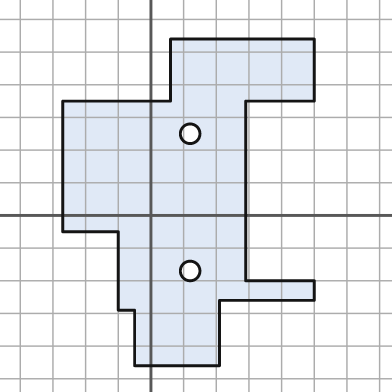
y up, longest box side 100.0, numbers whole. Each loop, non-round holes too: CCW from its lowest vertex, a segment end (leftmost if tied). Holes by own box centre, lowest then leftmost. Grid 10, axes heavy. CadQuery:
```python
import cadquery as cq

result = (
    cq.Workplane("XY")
    .moveTo(-5.0, -46.0)
    .lineTo(21.0, -46.0)
    .lineTo(21.0, -26.0)
    .lineTo(50.0, -26.0)
    .lineTo(50.0, -20.0)
    .lineTo(29.0, -20.0)
    .lineTo(29.0, 35.0)
    .lineTo(50.0, 35.0)
    .lineTo(50.0, 54.0)
    .lineTo(6.0, 54.0)
    .lineTo(6.0, 35.0)
    .lineTo(-27.0, 35.0)
    .lineTo(-27.0, -5.0)
    .lineTo(-10.0, -5.0)
    .lineTo(-10.0, -29.0)
    .lineTo(-5.0, -29.0)
    .close()
    .moveTo(12.0, -17.0)
    .circle(3.0)
    .moveTo(12.0, 25.0)
    .circle(3.0)
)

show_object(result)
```